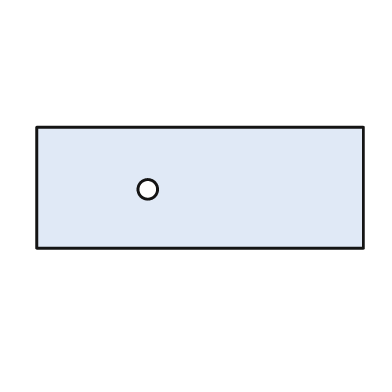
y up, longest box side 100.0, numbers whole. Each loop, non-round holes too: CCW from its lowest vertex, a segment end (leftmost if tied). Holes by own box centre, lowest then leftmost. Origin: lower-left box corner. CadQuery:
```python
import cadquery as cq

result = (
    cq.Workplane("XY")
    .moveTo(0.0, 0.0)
    .lineTo(100.0, 0.0)
    .lineTo(100.0, 37.0)
    .lineTo(0.0, 37.0)
    .close()
    .moveTo(34.0, 18.0)
    .circle(3.0)
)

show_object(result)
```